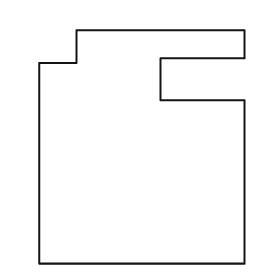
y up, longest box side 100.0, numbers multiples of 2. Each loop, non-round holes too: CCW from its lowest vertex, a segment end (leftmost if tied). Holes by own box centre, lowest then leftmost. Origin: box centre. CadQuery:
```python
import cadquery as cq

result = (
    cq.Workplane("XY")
    .moveTo(-44.0, -50.0)
    .lineTo(44.0, -50.0)
    .lineTo(44.0, 20.0)
    .lineTo(8.0, 20.0)
    .lineTo(8.0, 38.0)
    .lineTo(44.0, 38.0)
    .lineTo(44.0, 50.0)
    .lineTo(-28.0, 50.0)
    .lineTo(-28.0, 36.0)
    .lineTo(-44.0, 36.0)
    .close()
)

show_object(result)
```